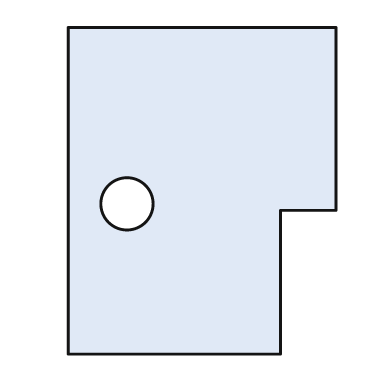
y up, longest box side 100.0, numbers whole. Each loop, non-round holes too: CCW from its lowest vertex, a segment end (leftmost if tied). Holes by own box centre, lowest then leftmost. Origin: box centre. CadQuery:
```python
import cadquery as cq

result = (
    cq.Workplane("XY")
    .moveTo(-41.0, -50.0)
    .lineTo(24.0, -50.0)
    .lineTo(24.0, -6.0)
    .lineTo(41.0, -6.0)
    .lineTo(41.0, 50.0)
    .lineTo(-41.0, 50.0)
    .close()
    .moveTo(-23.0, -4.0)
    .circle(8.0)
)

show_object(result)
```